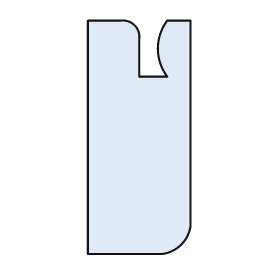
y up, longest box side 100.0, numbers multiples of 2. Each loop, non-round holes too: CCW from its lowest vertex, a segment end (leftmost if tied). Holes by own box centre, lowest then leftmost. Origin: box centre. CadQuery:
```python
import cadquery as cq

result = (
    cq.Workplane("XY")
    .moveTo(-22.0, -50.0)
    .lineTo(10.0, -50.0)
    .threePointArc((18.0, -46.0), (22.0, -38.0))
    .lineTo(22.0, 50.0)
    .lineTo(12.0, 50.0)
    .threePointArc((8.0, 38.0), (12.0, 26.0))
    .lineTo(0.0, 26.0)
    .lineTo(0.0, 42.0)
    .threePointArc((-2.0, 48.0), (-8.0, 50.0))
    .lineTo(-22.0, 50.0)
    .close()
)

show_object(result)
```